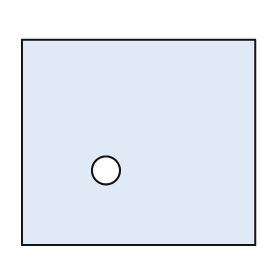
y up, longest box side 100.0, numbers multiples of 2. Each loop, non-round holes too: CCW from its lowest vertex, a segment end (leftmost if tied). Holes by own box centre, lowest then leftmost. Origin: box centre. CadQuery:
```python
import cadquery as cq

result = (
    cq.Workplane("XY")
    .moveTo(-50.0, -44.0)
    .lineTo(50.0, -44.0)
    .lineTo(50.0, 44.0)
    .lineTo(-50.0, 44.0)
    .close()
    .moveTo(-14.0, -12.0)
    .circle(6.0)
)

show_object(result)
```